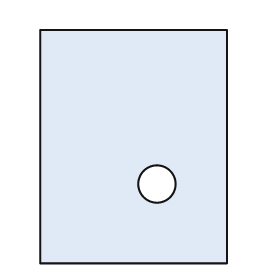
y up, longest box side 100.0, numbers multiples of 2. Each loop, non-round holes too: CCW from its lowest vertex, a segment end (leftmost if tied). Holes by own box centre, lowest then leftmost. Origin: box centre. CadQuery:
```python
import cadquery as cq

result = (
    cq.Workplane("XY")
    .moveTo(-40.0, -50.0)
    .lineTo(40.0, -50.0)
    .lineTo(40.0, 50.0)
    .lineTo(-40.0, 50.0)
    .close()
    .moveTo(10.0, -16.0)
    .circle(8.0)
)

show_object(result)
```